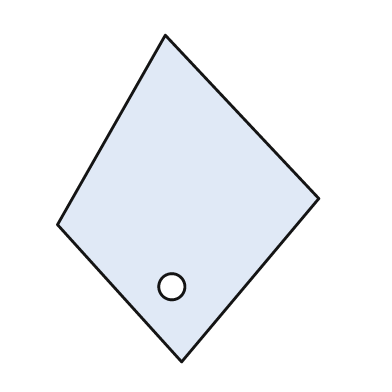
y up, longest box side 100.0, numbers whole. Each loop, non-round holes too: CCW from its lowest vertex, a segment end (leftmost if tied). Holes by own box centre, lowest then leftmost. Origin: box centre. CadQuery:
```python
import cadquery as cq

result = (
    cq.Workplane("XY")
    .moveTo(-2.0, -50.0)
    .lineTo(40.0, 0.0)
    .lineTo(-7.0, 50.0)
    .lineTo(-40.0, -8.0)
    .close()
    .moveTo(-5.0, -27.0)
    .circle(4.0)
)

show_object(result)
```